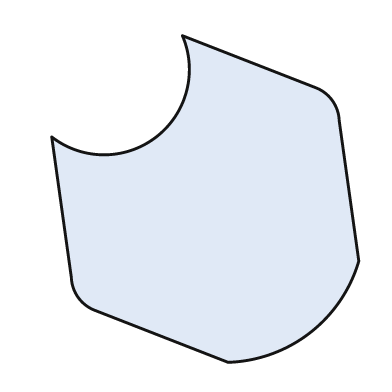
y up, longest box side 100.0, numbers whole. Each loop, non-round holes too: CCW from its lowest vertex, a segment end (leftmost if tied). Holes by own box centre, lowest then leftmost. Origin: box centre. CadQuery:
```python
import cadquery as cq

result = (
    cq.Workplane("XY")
    .moveTo(7.0, -50.0)
    .threePointArc((32.0, -41.0), (47.0, -19.0))
    .lineTo(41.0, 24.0)
    .threePointArc((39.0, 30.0), (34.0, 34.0))
    .lineTo(-7.0, 50.0)
    .threePointArc((-15.0, 19.0), (-47.0, 19.0))
    .lineTo(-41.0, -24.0)
    .threePointArc((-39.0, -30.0), (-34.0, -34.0))
    .close()
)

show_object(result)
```